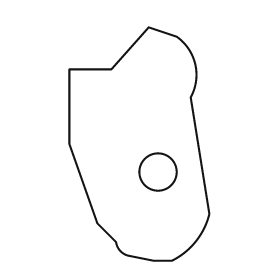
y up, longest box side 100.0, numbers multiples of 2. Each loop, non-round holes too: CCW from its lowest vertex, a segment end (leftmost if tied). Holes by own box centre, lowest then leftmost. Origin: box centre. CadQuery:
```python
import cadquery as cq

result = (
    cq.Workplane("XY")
    .moveTo(6.0, -50.0)
    .lineTo(14.0, -50.0)
    .threePointArc((24.0, -42.0), (30.0, -30.0))
    .lineTo(22.0, 20.0)
    .threePointArc((24.0, 34.0), (16.0, 46.0))
    .lineTo(4.0, 50.0)
    .lineTo(-12.0, 32.0)
    .lineTo(-30.0, 32.0)
    .lineTo(-30.0, 0.0)
    .lineTo(-18.0, -34.0)
    .lineTo(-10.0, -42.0)
    .threePointArc((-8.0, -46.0), (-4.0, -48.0))
    .close()
    .moveTo(8.0, -12.0)
    .circle(8.0)
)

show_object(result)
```